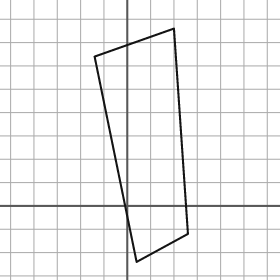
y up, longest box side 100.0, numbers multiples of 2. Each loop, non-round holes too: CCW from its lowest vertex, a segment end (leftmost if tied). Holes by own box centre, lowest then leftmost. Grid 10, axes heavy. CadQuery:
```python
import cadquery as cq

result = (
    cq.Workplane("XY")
    .moveTo(4.0, -24.0)
    .lineTo(26.0, -12.0)
    .lineTo(20.0, 76.0)
    .lineTo(-14.0, 64.0)
    .close()
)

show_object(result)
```